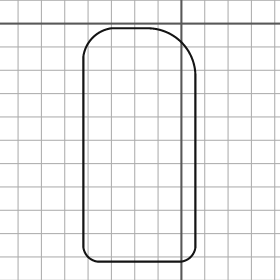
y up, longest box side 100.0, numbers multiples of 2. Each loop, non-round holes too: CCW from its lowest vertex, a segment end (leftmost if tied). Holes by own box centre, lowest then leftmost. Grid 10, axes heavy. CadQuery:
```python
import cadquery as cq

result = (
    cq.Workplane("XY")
    .moveTo(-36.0, -102.0)
    .lineTo(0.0, -102.0)
    .threePointArc((4.0, -100.0), (6.0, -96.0))
    .lineTo(6.0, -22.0)
    .threePointArc((0.0, -8.0), (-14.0, -2.0))
    .lineTo(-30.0, -2.0)
    .threePointArc((-38.0, -6.0), (-42.0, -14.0))
    .lineTo(-42.0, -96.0)
    .threePointArc((-40.0, -100.0), (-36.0, -102.0))
    .close()
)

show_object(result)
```